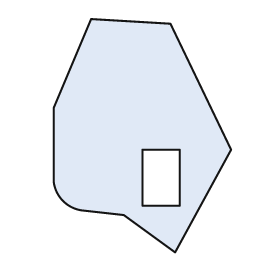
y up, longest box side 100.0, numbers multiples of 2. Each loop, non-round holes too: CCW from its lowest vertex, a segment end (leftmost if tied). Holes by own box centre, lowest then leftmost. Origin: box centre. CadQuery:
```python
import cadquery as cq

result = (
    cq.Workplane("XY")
    .moveTo(14.0, -50.0)
    .lineTo(38.0, -6.0)
    .lineTo(12.0, 48.0)
    .lineTo(-22.0, 50.0)
    .lineTo(-38.0, 12.0)
    .lineTo(-38.0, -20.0)
    .threePointArc((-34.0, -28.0), (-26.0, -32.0))
    .lineTo(-8.0, -34.0)
    .close()
    .moveTo(0.0, -30.0)
    .lineTo(16.0, -30.0)
    .lineTo(16.0, -6.0)
    .lineTo(0.0, -6.0)
    .close()
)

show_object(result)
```